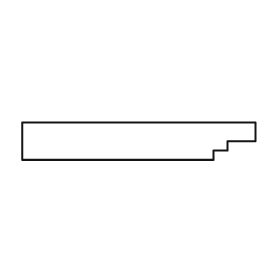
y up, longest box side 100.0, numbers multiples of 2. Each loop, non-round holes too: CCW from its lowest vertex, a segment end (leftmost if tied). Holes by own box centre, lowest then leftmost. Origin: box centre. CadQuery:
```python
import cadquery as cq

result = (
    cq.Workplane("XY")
    .moveTo(-50.0, -8.0)
    .lineTo(32.0, -8.0)
    .lineTo(32.0, -4.0)
    .lineTo(38.0, -4.0)
    .lineTo(38.0, 0.0)
    .lineTo(50.0, 0.0)
    .lineTo(50.0, 8.0)
    .lineTo(-50.0, 8.0)
    .close()
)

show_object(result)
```